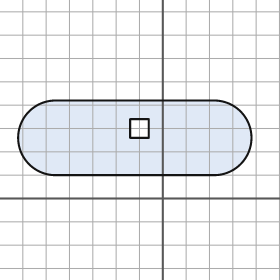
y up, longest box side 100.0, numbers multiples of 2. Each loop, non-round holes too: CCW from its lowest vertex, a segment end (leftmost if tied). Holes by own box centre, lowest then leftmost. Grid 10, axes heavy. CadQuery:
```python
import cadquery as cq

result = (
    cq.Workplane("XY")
    .moveTo(-46.0, 10.0)
    .lineTo(22.0, 10.0)
    .threePointArc((38.0, 26.0), (22.0, 42.0))
    .lineTo(-46.0, 42.0)
    .threePointArc((-62.0, 26.0), (-46.0, 10.0))
    .close()
    .moveTo(-14.0, 26.0)
    .lineTo(-6.0, 26.0)
    .lineTo(-6.0, 34.0)
    .lineTo(-14.0, 34.0)
    .close()
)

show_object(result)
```